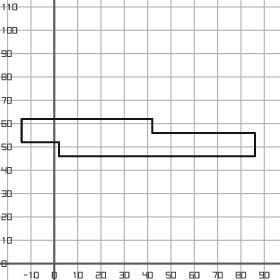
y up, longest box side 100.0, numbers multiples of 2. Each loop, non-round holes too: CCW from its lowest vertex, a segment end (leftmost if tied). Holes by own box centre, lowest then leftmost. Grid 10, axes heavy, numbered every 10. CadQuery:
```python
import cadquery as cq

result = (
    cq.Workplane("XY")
    .moveTo(2.0, 46.0)
    .lineTo(86.0, 46.0)
    .lineTo(86.0, 56.0)
    .lineTo(42.0, 56.0)
    .lineTo(42.0, 62.0)
    .lineTo(-14.0, 62.0)
    .lineTo(-14.0, 52.0)
    .lineTo(2.0, 52.0)
    .close()
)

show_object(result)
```